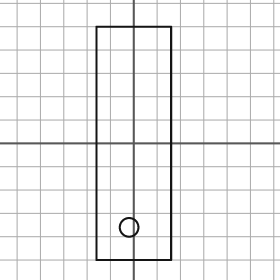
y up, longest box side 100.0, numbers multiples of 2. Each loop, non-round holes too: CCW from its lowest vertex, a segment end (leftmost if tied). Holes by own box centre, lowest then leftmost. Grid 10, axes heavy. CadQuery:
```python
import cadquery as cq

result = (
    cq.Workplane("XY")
    .moveTo(-16.0, -50.0)
    .lineTo(16.0, -50.0)
    .lineTo(16.0, 50.0)
    .lineTo(-16.0, 50.0)
    .close()
    .moveTo(-2.0, -36.0)
    .circle(4.0)
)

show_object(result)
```